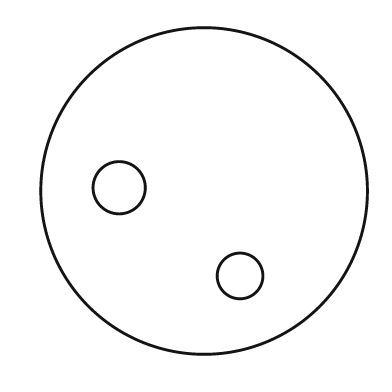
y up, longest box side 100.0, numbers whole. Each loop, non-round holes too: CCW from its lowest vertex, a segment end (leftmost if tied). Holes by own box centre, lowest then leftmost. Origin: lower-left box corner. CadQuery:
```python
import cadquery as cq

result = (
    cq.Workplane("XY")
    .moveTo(50.0, 50.0)
    .circle(50.0)
    .moveTo(61.0, 24.0)
    .circle(7.0)
    .moveTo(24.0, 51.0)
    .circle(8.0)
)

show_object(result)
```